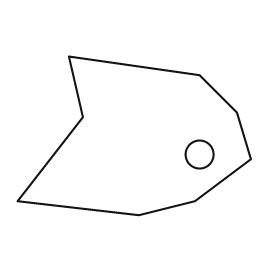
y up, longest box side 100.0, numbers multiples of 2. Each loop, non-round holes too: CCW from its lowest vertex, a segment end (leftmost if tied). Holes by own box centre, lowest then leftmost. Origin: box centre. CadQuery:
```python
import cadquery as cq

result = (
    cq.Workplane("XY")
    .moveTo(2.0, -34.0)
    .lineTo(26.0, -28.0)
    .lineTo(50.0, -10.0)
    .lineTo(44.0, 10.0)
    .lineTo(28.0, 26.0)
    .lineTo(-28.0, 34.0)
    .lineTo(-22.0, 8.0)
    .lineTo(-50.0, -28.0)
    .close()
    .moveTo(28.0, -8.0)
    .circle(6.0)
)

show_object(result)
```